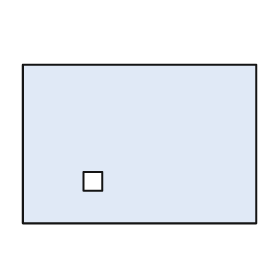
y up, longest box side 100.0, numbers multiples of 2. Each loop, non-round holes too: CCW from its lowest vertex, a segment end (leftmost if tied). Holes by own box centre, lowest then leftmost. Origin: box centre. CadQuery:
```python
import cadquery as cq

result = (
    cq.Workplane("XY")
    .moveTo(-50.0, -34.0)
    .lineTo(50.0, -34.0)
    .lineTo(50.0, 34.0)
    .lineTo(-50.0, 34.0)
    .close()
    .moveTo(-24.0, -20.0)
    .lineTo(-16.0, -20.0)
    .lineTo(-16.0, -12.0)
    .lineTo(-24.0, -12.0)
    .close()
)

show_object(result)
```